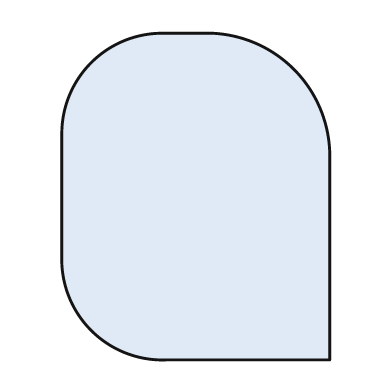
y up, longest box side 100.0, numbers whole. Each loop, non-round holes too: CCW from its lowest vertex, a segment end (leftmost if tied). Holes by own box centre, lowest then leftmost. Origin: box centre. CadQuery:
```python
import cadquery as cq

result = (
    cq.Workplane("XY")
    .moveTo(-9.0, -50.0)
    .lineTo(41.0, -50.0)
    .lineTo(41.0, 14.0)
    .threePointArc((30.0, 39.0), (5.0, 50.0))
    .lineTo(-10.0, 50.0)
    .threePointArc((-32.0, 41.0), (-41.0, 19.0))
    .lineTo(-41.0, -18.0)
    .threePointArc((-32.0, -41.0), (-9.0, -50.0))
    .close()
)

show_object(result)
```